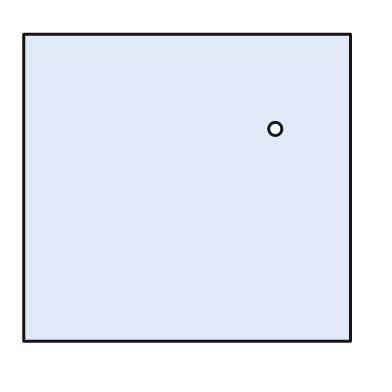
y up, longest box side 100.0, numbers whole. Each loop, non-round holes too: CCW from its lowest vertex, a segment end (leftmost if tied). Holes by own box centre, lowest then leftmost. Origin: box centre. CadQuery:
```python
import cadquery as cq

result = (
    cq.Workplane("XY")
    .moveTo(-50.0, -47.0)
    .lineTo(50.0, -47.0)
    .lineTo(50.0, 47.0)
    .lineTo(-50.0, 47.0)
    .close()
    .moveTo(27.0, 18.0)
    .circle(2.0)
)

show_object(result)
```